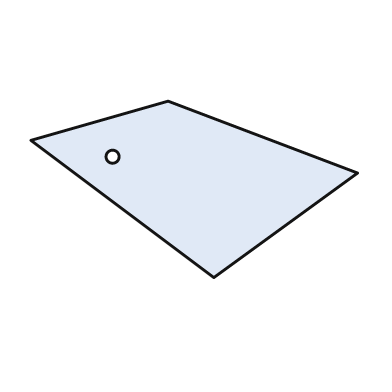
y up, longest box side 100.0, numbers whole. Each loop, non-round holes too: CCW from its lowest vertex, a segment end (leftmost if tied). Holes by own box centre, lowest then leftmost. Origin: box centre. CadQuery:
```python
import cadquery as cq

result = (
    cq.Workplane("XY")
    .moveTo(6.0, -27.0)
    .lineTo(50.0, 5.0)
    .lineTo(-8.0, 27.0)
    .lineTo(-50.0, 15.0)
    .close()
    .moveTo(-25.0, 10.0)
    .circle(2.0)
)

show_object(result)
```